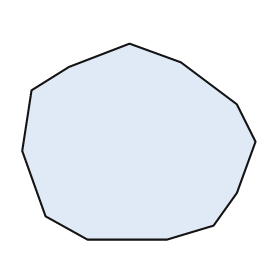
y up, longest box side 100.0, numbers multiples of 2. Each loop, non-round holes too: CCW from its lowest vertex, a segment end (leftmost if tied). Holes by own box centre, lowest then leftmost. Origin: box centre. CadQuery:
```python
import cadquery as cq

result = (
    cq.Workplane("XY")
    .moveTo(-22.0, -42.0)
    .lineTo(12.0, -42.0)
    .lineTo(32.0, -36.0)
    .lineTo(42.0, -22.0)
    .lineTo(50.0, 0.0)
    .lineTo(42.0, 16.0)
    .lineTo(18.0, 34.0)
    .lineTo(-4.0, 42.0)
    .lineTo(-30.0, 32.0)
    .lineTo(-46.0, 22.0)
    .lineTo(-50.0, -4.0)
    .lineTo(-40.0, -32.0)
    .close()
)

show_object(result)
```